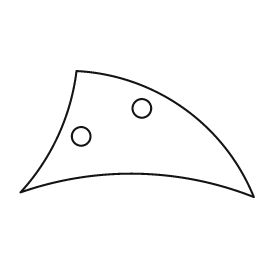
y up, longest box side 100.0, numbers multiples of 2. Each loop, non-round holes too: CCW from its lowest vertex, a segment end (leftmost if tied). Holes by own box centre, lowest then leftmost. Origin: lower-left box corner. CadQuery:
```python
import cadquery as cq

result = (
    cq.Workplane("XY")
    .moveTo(100.0, 0.0)
    .threePointArc((70.0, 38.0), (24.0, 54.0))
    .threePointArc((16.0, 26.0), (0.0, 2.0))
    .threePointArc((50.0, 10.0), (100.0, 0.0))
    .close()
    .moveTo(26.0, 26.0)
    .circle(4.0)
    .moveTo(52.0, 38.0)
    .circle(4.0)
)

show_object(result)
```